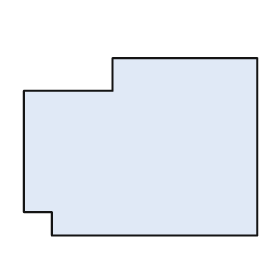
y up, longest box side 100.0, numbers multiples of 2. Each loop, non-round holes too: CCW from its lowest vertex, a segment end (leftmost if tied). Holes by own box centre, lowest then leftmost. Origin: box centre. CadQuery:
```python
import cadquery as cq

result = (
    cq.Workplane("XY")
    .moveTo(-38.0, -38.0)
    .lineTo(50.0, -38.0)
    .lineTo(50.0, 38.0)
    .lineTo(-12.0, 38.0)
    .lineTo(-12.0, 24.0)
    .lineTo(-50.0, 24.0)
    .lineTo(-50.0, -28.0)
    .lineTo(-38.0, -28.0)
    .close()
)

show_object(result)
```